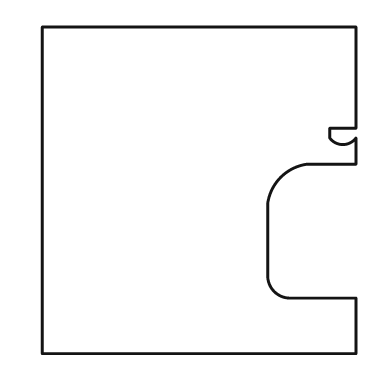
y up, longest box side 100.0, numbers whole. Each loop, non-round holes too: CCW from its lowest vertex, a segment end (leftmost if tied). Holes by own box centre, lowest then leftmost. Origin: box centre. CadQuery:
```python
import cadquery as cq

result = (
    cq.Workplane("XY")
    .moveTo(-48.0, -50.0)
    .lineTo(48.0, -50.0)
    .lineTo(48.0, -33.0)
    .lineTo(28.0, -33.0)
    .threePointArc((23.0, -31.0), (21.0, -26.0))
    .lineTo(21.0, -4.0)
    .threePointArc((25.0, 4.0), (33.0, 8.0))
    .lineTo(48.0, 8.0)
    .lineTo(48.0, 16.0)
    .threePointArc((44.0, 14.0), (40.0, 16.0))
    .lineTo(40.0, 19.0)
    .lineTo(48.0, 19.0)
    .lineTo(48.0, 50.0)
    .lineTo(-48.0, 50.0)
    .close()
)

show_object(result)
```